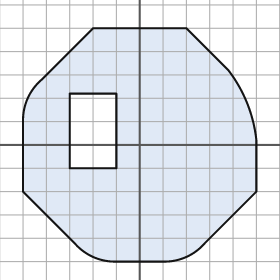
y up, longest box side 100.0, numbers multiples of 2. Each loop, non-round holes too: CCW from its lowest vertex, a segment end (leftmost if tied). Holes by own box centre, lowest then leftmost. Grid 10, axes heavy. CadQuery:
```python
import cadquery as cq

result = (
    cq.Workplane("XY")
    .moveTo(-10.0, -50.0)
    .lineTo(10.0, -50.0)
    .threePointArc((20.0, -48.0), (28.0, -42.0))
    .lineTo(50.0, -20.0)
    .lineTo(50.0, 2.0)
    .threePointArc((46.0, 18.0), (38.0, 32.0))
    .lineTo(20.0, 50.0)
    .lineTo(-20.0, 50.0)
    .lineTo(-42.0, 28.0)
    .threePointArc((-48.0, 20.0), (-50.0, 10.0))
    .lineTo(-50.0, -20.0)
    .lineTo(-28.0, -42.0)
    .threePointArc((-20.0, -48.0), (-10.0, -50.0))
    .close()
    .moveTo(-30.0, -10.0)
    .lineTo(-10.0, -10.0)
    .lineTo(-10.0, 22.0)
    .lineTo(-30.0, 22.0)
    .close()
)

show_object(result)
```